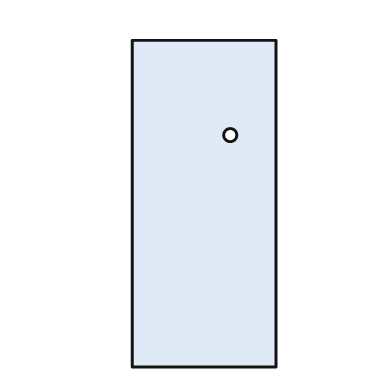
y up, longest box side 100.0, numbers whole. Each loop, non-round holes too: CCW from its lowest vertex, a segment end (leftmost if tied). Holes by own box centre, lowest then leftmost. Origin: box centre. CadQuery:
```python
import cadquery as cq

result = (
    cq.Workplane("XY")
    .moveTo(-22.0, -50.0)
    .lineTo(22.0, -50.0)
    .lineTo(22.0, 50.0)
    .lineTo(-22.0, 50.0)
    .close()
    .moveTo(8.0, 21.0)
    .circle(2.0)
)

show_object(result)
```